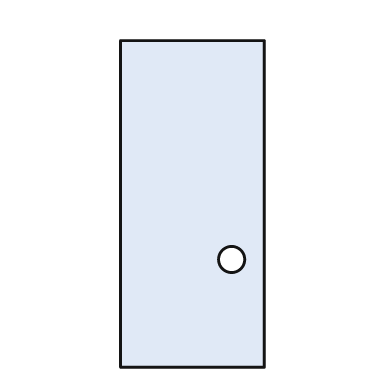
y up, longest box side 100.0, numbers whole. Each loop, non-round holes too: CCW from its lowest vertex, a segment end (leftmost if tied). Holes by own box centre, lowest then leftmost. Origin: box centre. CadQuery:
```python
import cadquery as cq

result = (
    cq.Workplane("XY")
    .moveTo(-22.0, -50.0)
    .lineTo(22.0, -50.0)
    .lineTo(22.0, 50.0)
    .lineTo(-22.0, 50.0)
    .close()
    .moveTo(12.0, -17.0)
    .circle(4.0)
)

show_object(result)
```